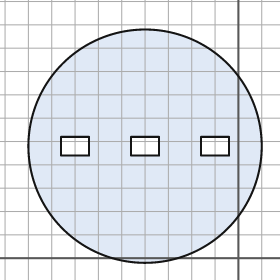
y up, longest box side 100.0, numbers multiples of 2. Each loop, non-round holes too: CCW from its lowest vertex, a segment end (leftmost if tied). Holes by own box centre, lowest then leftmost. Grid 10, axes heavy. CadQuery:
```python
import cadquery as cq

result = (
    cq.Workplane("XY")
    .moveTo(-40.0, 48.0)
    .circle(50.0)
    .moveTo(-76.0, 44.0)
    .lineTo(-64.0, 44.0)
    .lineTo(-64.0, 52.0)
    .lineTo(-76.0, 52.0)
    .close()
    .moveTo(-46.0, 44.0)
    .lineTo(-34.0, 44.0)
    .lineTo(-34.0, 52.0)
    .lineTo(-46.0, 52.0)
    .close()
    .moveTo(-16.0, 44.0)
    .lineTo(-4.0, 44.0)
    .lineTo(-4.0, 52.0)
    .lineTo(-16.0, 52.0)
    .close()
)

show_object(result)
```